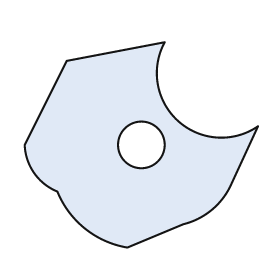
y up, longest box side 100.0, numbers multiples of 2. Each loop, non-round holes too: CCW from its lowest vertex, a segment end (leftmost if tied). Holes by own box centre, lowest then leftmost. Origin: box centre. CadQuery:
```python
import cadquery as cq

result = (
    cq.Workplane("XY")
    .moveTo(-6.0, -44.0)
    .lineTo(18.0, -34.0)
    .threePointArc((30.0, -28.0), (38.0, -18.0))
    .lineTo(50.0, 8.0)
    .threePointArc((16.0, 10.0), (10.0, 44.0))
    .lineTo(-32.0, 36.0)
    .lineTo(-50.0, 0.0)
    .threePointArc((-46.0, -12.0), (-36.0, -20.0))
    .threePointArc((-24.0, -36.0), (-6.0, -44.0))
    .close()
    .moveTo(0.0, 0.0)
    .circle(10.0)
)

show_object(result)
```